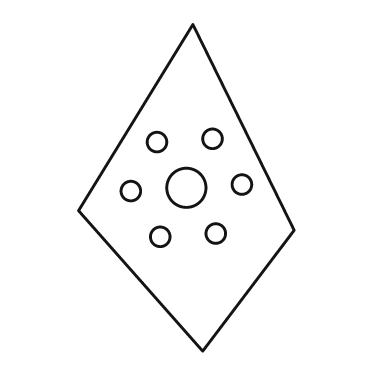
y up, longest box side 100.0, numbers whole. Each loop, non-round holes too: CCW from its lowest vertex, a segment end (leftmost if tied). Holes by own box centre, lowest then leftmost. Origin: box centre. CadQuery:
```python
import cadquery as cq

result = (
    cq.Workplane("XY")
    .moveTo(5.0, -50.0)
    .lineTo(33.0, -13.0)
    .lineTo(2.0, 50.0)
    .lineTo(-33.0, -7.0)
    .close()
    .moveTo(-8.0, -15.0)
    .circle(3.0)
    .moveTo(9.0, -14.0)
    .circle(3.0)
    .moveTo(-17.0, -1.0)
    .circle(3.0)
    .moveTo(0.0, 0.0)
    .circle(6.0)
    .moveTo(17.0, 1.0)
    .circle(3.0)
    .moveTo(-9.0, 14.0)
    .circle(3.0)
    .moveTo(8.0, 15.0)
    .circle(3.0)
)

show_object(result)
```